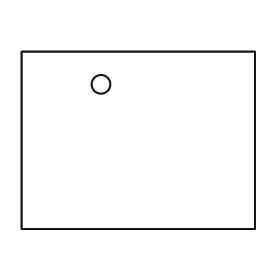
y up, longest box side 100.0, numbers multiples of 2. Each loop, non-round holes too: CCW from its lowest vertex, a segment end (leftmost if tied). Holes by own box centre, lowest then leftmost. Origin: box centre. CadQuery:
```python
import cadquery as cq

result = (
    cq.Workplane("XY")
    .moveTo(-50.0, -38.0)
    .lineTo(50.0, -38.0)
    .lineTo(50.0, 38.0)
    .lineTo(-50.0, 38.0)
    .close()
    .moveTo(-16.0, 24.0)
    .circle(4.0)
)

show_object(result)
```